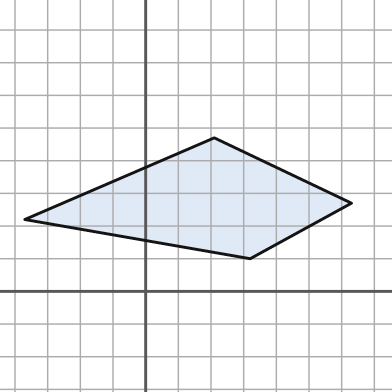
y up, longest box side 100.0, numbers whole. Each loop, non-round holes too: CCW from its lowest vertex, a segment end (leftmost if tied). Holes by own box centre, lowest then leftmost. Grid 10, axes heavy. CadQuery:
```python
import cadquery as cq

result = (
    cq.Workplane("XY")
    .moveTo(32.0, 10.0)
    .lineTo(63.0, 27.0)
    .lineTo(21.0, 47.0)
    .lineTo(-37.0, 22.0)
    .close()
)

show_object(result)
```